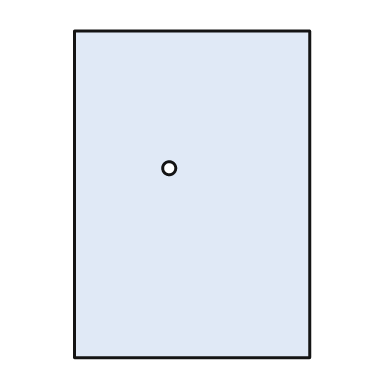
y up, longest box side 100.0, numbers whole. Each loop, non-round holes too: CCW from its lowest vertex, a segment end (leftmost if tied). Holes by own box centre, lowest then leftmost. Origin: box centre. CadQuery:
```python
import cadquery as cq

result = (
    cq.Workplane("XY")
    .moveTo(-36.0, -50.0)
    .lineTo(36.0, -50.0)
    .lineTo(36.0, 50.0)
    .lineTo(-36.0, 50.0)
    .close()
    .moveTo(-7.0, 8.0)
    .circle(2.0)
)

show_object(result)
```